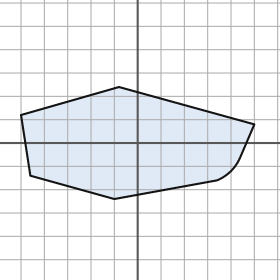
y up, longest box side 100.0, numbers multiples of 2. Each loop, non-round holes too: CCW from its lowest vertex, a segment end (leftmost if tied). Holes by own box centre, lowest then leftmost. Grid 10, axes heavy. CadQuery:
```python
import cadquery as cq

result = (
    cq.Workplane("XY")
    .moveTo(-10.0, -24.0)
    .lineTo(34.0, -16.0)
    .threePointArc((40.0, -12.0), (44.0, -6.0))
    .lineTo(50.0, 8.0)
    .lineTo(-8.0, 24.0)
    .lineTo(-50.0, 12.0)
    .lineTo(-46.0, -14.0)
    .close()
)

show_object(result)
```